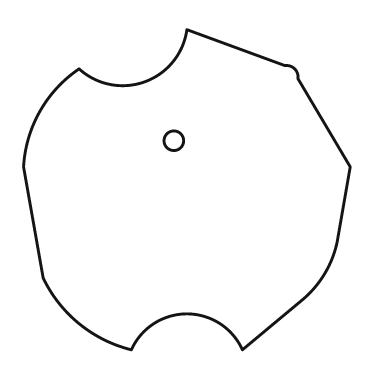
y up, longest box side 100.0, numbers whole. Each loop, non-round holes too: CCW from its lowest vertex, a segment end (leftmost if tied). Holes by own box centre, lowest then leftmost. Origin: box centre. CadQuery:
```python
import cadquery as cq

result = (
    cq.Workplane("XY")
    .moveTo(-17.0, -49.0)
    .threePointArc((0.0, -38.0), (17.0, -49.0))
    .lineTo(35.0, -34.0)
    .threePointArc((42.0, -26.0), (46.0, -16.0))
    .lineTo(50.0, 7.0)
    .lineTo(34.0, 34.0)
    .threePointArc((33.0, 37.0), (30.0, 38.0))
    .lineTo(0.0, 49.0)
    .threePointArc((-13.0, 33.0), (-33.0, 37.0))
    .threePointArc((-45.0, 24.0), (-50.0, 7.0))
    .lineTo(-44.0, -27.0)
    .threePointArc((-33.0, -41.0), (-17.0, -49.0))
    .close()
    .moveTo(-4.0, 15.0)
    .circle(3.0)
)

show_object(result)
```